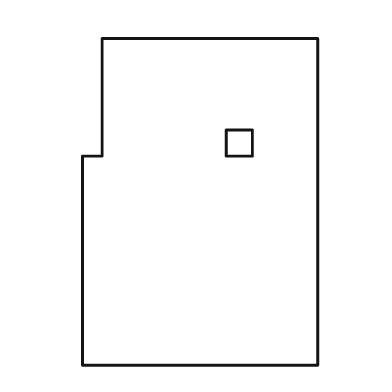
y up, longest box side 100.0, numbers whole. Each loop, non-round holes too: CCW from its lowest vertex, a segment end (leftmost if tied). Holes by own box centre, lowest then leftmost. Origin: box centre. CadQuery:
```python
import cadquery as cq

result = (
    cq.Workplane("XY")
    .moveTo(-36.0, -50.0)
    .lineTo(36.0, -50.0)
    .lineTo(36.0, 50.0)
    .lineTo(-30.0, 50.0)
    .lineTo(-30.0, 14.0)
    .lineTo(-36.0, 14.0)
    .close()
    .moveTo(8.0, 14.0)
    .lineTo(16.0, 14.0)
    .lineTo(16.0, 22.0)
    .lineTo(8.0, 22.0)
    .close()
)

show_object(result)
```